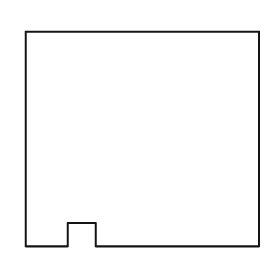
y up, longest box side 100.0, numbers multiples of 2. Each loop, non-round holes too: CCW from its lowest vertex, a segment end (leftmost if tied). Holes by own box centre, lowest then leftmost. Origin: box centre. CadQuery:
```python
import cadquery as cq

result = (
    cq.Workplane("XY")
    .moveTo(-50.0, -46.0)
    .lineTo(-32.0, -46.0)
    .lineTo(-32.0, -36.0)
    .lineTo(-20.0, -36.0)
    .lineTo(-20.0, -46.0)
    .lineTo(50.0, -46.0)
    .lineTo(50.0, 46.0)
    .lineTo(-50.0, 46.0)
    .close()
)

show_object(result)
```